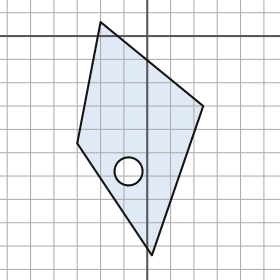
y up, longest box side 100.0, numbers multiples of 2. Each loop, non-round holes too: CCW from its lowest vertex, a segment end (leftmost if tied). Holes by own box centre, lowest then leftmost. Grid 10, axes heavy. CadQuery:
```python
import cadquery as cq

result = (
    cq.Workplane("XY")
    .moveTo(2.0, -94.0)
    .lineTo(24.0, -30.0)
    .lineTo(-20.0, 6.0)
    .lineTo(-30.0, -46.0)
    .close()
    .moveTo(-8.0, -58.0)
    .circle(6.0)
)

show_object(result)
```